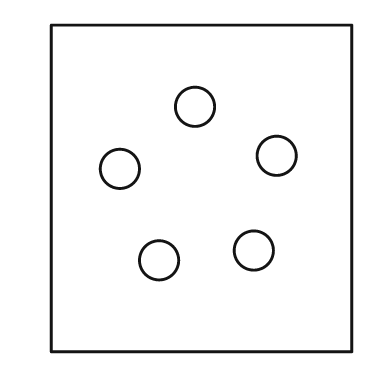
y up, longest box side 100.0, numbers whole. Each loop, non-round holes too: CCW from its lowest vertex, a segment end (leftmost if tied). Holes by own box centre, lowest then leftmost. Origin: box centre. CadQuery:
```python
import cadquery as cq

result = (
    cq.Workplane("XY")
    .moveTo(-46.0, -50.0)
    .lineTo(46.0, -50.0)
    .lineTo(46.0, 50.0)
    .lineTo(-46.0, 50.0)
    .close()
    .moveTo(-13.0, -22.0)
    .circle(6.0)
    .moveTo(16.0, -19.0)
    .circle(6.0)
    .moveTo(-25.0, 6.0)
    .circle(6.0)
    .moveTo(23.0, 10.0)
    .circle(6.0)
    .moveTo(-2.0, 25.0)
    .circle(6.0)
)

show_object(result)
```